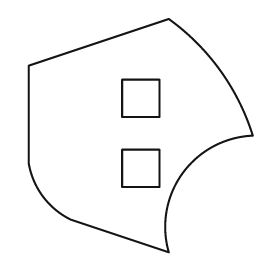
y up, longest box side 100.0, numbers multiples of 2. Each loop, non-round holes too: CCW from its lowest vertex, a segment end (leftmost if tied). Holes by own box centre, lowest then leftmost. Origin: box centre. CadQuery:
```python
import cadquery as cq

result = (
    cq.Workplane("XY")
    .moveTo(12.0, -50.0)
    .threePointArc((18.0, -16.0), (48.0, 0.0))
    .threePointArc((34.0, 28.0), (12.0, 50.0))
    .lineTo(-48.0, 30.0)
    .lineTo(-48.0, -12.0)
    .threePointArc((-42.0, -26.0), (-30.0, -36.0))
    .close()
    .moveTo(-8.0, -22.0)
    .lineTo(8.0, -22.0)
    .lineTo(8.0, -6.0)
    .lineTo(-8.0, -6.0)
    .close()
    .moveTo(-8.0, 8.0)
    .lineTo(8.0, 8.0)
    .lineTo(8.0, 24.0)
    .lineTo(-8.0, 24.0)
    .close()
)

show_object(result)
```